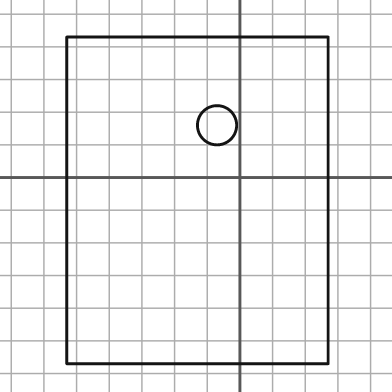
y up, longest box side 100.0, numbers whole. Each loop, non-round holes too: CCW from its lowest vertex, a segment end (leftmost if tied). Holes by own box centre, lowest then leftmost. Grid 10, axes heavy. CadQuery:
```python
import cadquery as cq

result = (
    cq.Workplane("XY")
    .moveTo(-53.0, -57.0)
    .lineTo(27.0, -57.0)
    .lineTo(27.0, 43.0)
    .lineTo(-53.0, 43.0)
    .close()
    .moveTo(-7.0, 16.0)
    .circle(6.0)
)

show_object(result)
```